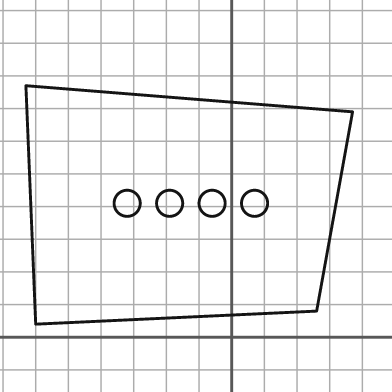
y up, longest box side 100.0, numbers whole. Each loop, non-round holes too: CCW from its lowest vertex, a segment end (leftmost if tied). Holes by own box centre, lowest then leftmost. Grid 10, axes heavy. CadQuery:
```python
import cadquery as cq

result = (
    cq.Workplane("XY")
    .moveTo(-60.0, 4.0)
    .lineTo(26.0, 8.0)
    .lineTo(37.0, 69.0)
    .lineTo(-63.0, 77.0)
    .close()
    .moveTo(-32.0, 41.0)
    .circle(4.0)
    .moveTo(-19.0, 41.0)
    .circle(4.0)
    .moveTo(-6.0, 41.0)
    .circle(4.0)
    .moveTo(7.0, 41.0)
    .circle(4.0)
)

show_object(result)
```